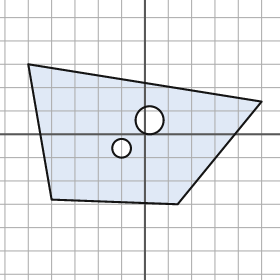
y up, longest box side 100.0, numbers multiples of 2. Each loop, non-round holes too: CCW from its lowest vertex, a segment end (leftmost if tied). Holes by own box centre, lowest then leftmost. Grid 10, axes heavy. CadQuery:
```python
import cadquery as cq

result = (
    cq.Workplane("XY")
    .moveTo(14.0, -30.0)
    .lineTo(50.0, 14.0)
    .lineTo(-50.0, 30.0)
    .lineTo(-40.0, -28.0)
    .close()
    .moveTo(-10.0, -6.0)
    .circle(4.0)
    .moveTo(2.0, 6.0)
    .circle(6.0)
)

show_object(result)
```